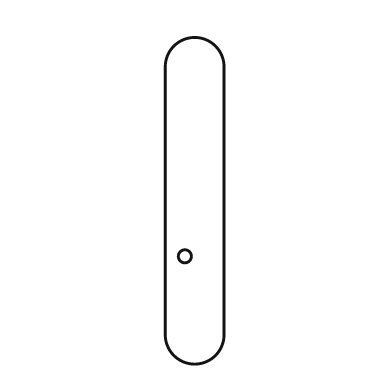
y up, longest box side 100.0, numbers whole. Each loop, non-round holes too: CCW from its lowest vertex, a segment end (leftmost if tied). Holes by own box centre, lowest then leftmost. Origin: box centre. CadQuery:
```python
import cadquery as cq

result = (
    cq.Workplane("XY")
    .moveTo(-9.0, -41.0)
    .threePointArc((0.0, -50.0), (9.0, -41.0))
    .lineTo(9.0, 41.0)
    .threePointArc((0.0, 50.0), (-9.0, 41.0))
    .close()
    .moveTo(-3.0, -17.0)
    .circle(2.0)
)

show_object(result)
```